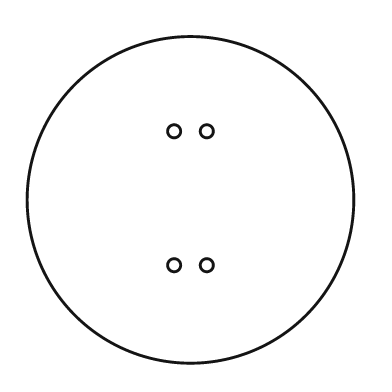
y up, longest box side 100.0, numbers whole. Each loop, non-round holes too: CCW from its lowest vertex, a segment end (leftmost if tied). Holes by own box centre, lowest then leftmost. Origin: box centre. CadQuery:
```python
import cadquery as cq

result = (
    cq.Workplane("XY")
    .moveTo(0.0, 0.0)
    .circle(50.0)
    .moveTo(-5.0, -20.0)
    .circle(2.0)
    .moveTo(5.0, -20.0)
    .circle(2.0)
    .moveTo(-5.0, 21.0)
    .circle(2.0)
    .moveTo(5.0, 21.0)
    .circle(2.0)
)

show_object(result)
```